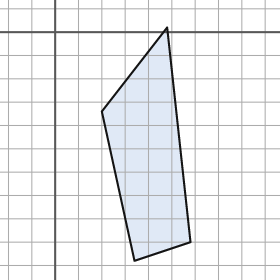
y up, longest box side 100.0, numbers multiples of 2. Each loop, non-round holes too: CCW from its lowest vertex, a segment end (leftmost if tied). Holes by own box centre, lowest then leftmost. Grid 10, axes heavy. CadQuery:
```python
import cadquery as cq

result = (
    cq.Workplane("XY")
    .moveTo(34.0, -98.0)
    .lineTo(58.0, -90.0)
    .lineTo(48.0, 2.0)
    .lineTo(20.0, -34.0)
    .close()
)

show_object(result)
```